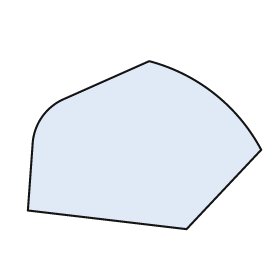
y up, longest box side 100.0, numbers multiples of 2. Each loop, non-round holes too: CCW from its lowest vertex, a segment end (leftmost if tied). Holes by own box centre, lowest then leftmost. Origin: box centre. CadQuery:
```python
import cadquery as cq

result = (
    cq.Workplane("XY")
    .moveTo(18.0, -36.0)
    .lineTo(50.0, -2.0)
    .threePointArc((30.0, 22.0), (2.0, 36.0))
    .lineTo(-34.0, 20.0)
    .threePointArc((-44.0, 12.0), (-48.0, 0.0))
    .lineTo(-50.0, -28.0)
    .close()
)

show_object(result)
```